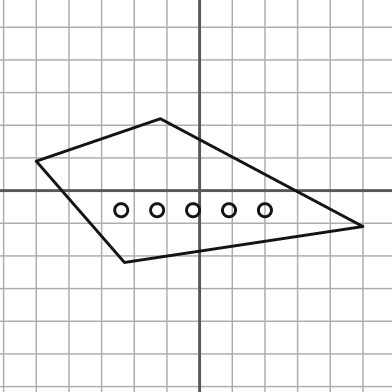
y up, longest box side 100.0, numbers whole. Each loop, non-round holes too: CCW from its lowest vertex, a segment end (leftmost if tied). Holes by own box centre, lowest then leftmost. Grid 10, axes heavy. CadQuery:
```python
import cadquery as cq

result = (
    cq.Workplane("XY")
    .moveTo(-23.0, -22.0)
    .lineTo(50.0, -11.0)
    .lineTo(-12.0, 22.0)
    .lineTo(-50.0, 9.0)
    .close()
    .moveTo(-24.0, -6.0)
    .circle(2.0)
    .moveTo(-13.0, -6.0)
    .circle(2.0)
    .moveTo(-2.0, -6.0)
    .circle(2.0)
    .moveTo(9.0, -6.0)
    .circle(2.0)
    .moveTo(20.0, -6.0)
    .circle(2.0)
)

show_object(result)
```